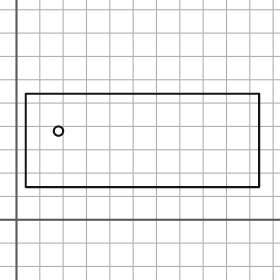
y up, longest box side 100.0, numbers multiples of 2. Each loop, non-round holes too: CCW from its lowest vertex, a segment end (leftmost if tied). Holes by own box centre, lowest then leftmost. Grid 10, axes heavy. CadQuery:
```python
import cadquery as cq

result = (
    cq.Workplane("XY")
    .moveTo(4.0, 14.0)
    .lineTo(104.0, 14.0)
    .lineTo(104.0, 54.0)
    .lineTo(4.0, 54.0)
    .close()
    .moveTo(18.0, 38.0)
    .circle(2.0)
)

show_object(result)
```